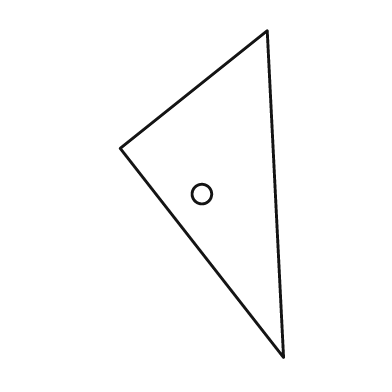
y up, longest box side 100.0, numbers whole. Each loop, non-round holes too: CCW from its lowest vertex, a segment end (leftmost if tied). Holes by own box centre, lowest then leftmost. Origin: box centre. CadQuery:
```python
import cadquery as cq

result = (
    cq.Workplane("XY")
    .moveTo(25.0, -50.0)
    .lineTo(20.0, 50.0)
    .lineTo(-25.0, 14.0)
    .close()
    .moveTo(0.0, 0.0)
    .circle(3.0)
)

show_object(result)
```